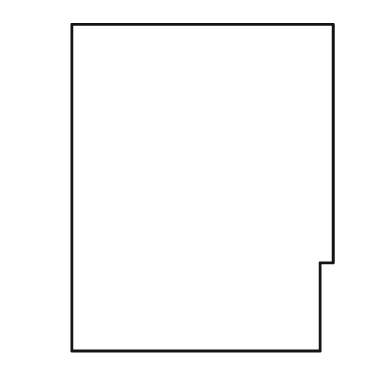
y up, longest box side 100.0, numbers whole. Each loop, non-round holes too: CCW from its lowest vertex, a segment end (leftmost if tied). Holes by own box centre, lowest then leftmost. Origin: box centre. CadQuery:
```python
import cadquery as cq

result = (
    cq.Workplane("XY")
    .moveTo(-40.0, -50.0)
    .lineTo(36.0, -50.0)
    .lineTo(36.0, -23.0)
    .lineTo(40.0, -23.0)
    .lineTo(40.0, 50.0)
    .lineTo(-40.0, 50.0)
    .close()
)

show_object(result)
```